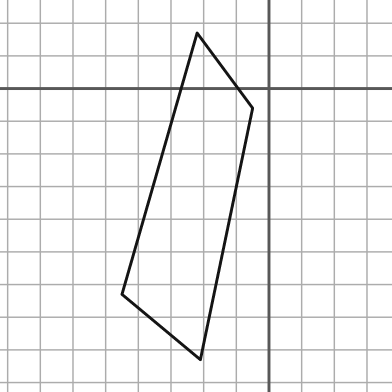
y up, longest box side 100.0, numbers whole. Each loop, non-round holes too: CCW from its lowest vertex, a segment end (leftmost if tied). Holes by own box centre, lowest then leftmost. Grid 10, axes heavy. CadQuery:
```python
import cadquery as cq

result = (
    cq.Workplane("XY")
    .moveTo(-21.0, -83.0)
    .lineTo(-5.0, -6.0)
    .lineTo(-22.0, 17.0)
    .lineTo(-45.0, -63.0)
    .close()
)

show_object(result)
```